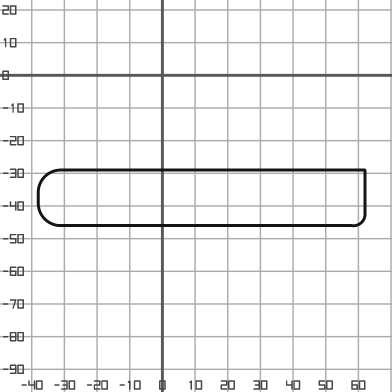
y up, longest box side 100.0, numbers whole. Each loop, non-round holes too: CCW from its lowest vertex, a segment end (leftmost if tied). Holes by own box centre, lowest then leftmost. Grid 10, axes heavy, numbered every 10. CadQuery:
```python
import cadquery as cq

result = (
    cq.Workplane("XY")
    .moveTo(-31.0, -46.0)
    .lineTo(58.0, -46.0)
    .threePointArc((61.0, -45.0), (62.0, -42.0))
    .lineTo(62.0, -29.0)
    .lineTo(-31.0, -29.0)
    .threePointArc((-36.0, -31.0), (-38.0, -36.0))
    .lineTo(-38.0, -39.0)
    .threePointArc((-36.0, -44.0), (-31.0, -46.0))
    .close()
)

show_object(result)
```